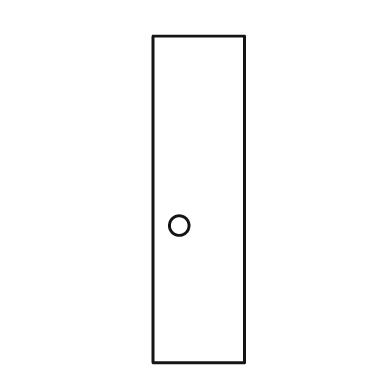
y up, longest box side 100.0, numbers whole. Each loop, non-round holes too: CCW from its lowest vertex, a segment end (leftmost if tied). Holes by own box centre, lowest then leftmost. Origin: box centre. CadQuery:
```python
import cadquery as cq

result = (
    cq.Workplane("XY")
    .moveTo(-14.0, -50.0)
    .lineTo(14.0, -50.0)
    .lineTo(14.0, 50.0)
    .lineTo(-14.0, 50.0)
    .close()
    .moveTo(-6.0, -8.0)
    .circle(3.0)
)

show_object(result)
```